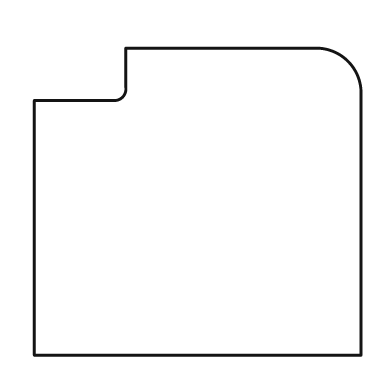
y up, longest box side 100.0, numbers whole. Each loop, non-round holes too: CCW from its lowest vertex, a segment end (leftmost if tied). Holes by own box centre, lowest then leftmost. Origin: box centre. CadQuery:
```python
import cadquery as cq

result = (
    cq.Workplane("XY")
    .moveTo(-50.0, -47.0)
    .lineTo(50.0, -47.0)
    .lineTo(50.0, 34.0)
    .threePointArc((46.0, 43.0), (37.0, 47.0))
    .lineTo(-22.0, 47.0)
    .lineTo(-22.0, 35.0)
    .threePointArc((-23.0, 32.0), (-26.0, 31.0))
    .lineTo(-50.0, 31.0)
    .close()
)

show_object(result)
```